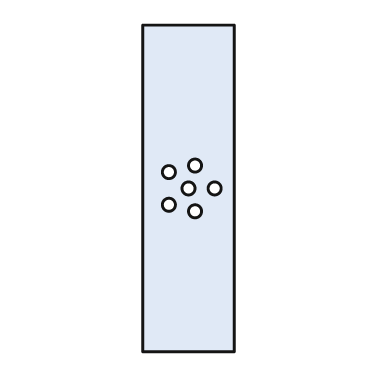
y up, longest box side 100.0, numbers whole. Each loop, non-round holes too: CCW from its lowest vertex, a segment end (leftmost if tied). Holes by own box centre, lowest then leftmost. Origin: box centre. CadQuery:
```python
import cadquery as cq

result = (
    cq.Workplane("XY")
    .moveTo(-14.0, -50.0)
    .lineTo(14.0, -50.0)
    .lineTo(14.0, 50.0)
    .lineTo(-14.0, 50.0)
    .close()
    .moveTo(2.0, -7.0)
    .circle(2.0)
    .moveTo(-6.0, -5.0)
    .circle(2.0)
    .moveTo(0.0, 0.0)
    .circle(2.0)
    .moveTo(8.0, 0.0)
    .circle(2.0)
    .moveTo(-6.0, 5.0)
    .circle(2.0)
    .moveTo(2.0, 7.0)
    .circle(2.0)
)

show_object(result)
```